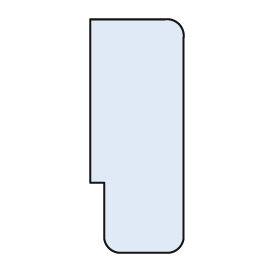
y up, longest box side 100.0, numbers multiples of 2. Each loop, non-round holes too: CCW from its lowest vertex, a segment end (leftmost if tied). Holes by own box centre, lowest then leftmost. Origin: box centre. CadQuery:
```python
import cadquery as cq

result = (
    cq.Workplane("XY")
    .moveTo(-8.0, -50.0)
    .lineTo(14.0, -50.0)
    .threePointArc((18.0, -48.0), (20.0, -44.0))
    .lineTo(20.0, 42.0)
    .threePointArc((18.0, 48.0), (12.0, 50.0))
    .lineTo(-20.0, 50.0)
    .lineTo(-20.0, -20.0)
    .lineTo(-14.0, -20.0)
    .lineTo(-14.0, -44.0)
    .threePointArc((-12.0, -48.0), (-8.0, -50.0))
    .close()
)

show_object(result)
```